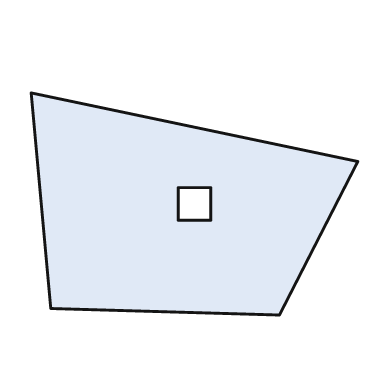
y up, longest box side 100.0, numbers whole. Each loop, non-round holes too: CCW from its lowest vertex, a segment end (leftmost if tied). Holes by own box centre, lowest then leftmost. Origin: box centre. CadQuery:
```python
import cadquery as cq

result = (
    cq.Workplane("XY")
    .moveTo(26.0, -34.0)
    .lineTo(50.0, 13.0)
    .lineTo(-50.0, 34.0)
    .lineTo(-44.0, -32.0)
    .close()
    .moveTo(-5.0, -5.0)
    .lineTo(5.0, -5.0)
    .lineTo(5.0, 5.0)
    .lineTo(-5.0, 5.0)
    .close()
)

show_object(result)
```